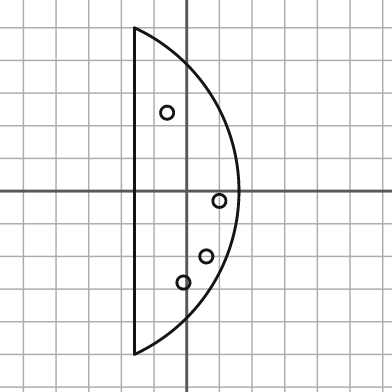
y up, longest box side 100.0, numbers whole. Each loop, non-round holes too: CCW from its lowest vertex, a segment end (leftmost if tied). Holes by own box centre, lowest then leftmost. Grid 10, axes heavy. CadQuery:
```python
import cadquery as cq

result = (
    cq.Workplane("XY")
    .moveTo(-16.0, -50.0)
    .threePointArc((16.0, 0.0), (-16.0, 50.0))
    .close()
    .moveTo(-1.0, -28.0)
    .circle(2.0)
    .moveTo(6.0, -20.0)
    .circle(2.0)
    .moveTo(10.0, -3.0)
    .circle(2.0)
    .moveTo(-6.0, 24.0)
    .circle(2.0)
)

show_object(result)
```